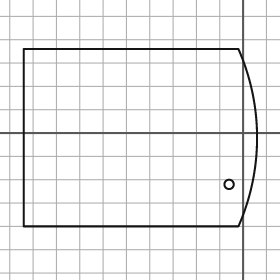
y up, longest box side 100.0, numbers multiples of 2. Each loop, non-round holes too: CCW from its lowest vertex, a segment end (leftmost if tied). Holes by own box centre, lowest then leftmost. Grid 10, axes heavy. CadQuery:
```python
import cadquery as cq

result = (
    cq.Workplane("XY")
    .moveTo(-94.0, -40.0)
    .lineTo(-2.0, -40.0)
    .threePointArc((6.0, -2.0), (-2.0, 36.0))
    .lineTo(-94.0, 36.0)
    .close()
    .moveTo(-6.0, -22.0)
    .circle(2.0)
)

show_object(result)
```